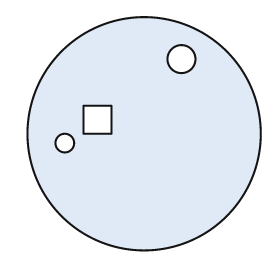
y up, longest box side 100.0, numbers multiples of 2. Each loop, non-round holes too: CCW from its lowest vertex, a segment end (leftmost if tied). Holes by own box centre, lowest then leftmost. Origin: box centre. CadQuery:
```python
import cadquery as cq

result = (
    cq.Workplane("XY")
    .moveTo(0.0, 0.0)
    .circle(50.0)
    .moveTo(-34.0, -4.0)
    .circle(4.0)
    .moveTo(-26.0, 0.0)
    .lineTo(-14.0, 0.0)
    .lineTo(-14.0, 12.0)
    .lineTo(-26.0, 12.0)
    .close()
    .moveTo(16.0, 32.0)
    .circle(6.0)
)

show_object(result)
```